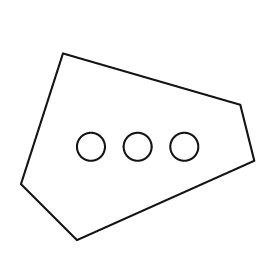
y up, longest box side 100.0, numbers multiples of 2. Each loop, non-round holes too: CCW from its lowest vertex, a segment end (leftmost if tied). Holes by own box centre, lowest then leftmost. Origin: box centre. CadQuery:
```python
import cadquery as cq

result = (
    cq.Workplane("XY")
    .moveTo(-26.0, -40.0)
    .lineTo(50.0, -6.0)
    .lineTo(44.0, 18.0)
    .lineTo(-32.0, 40.0)
    .lineTo(-50.0, -16.0)
    .close()
    .moveTo(-20.0, 0.0)
    .circle(6.0)
    .moveTo(0.0, 0.0)
    .circle(6.0)
    .moveTo(20.0, 0.0)
    .circle(6.0)
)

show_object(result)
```